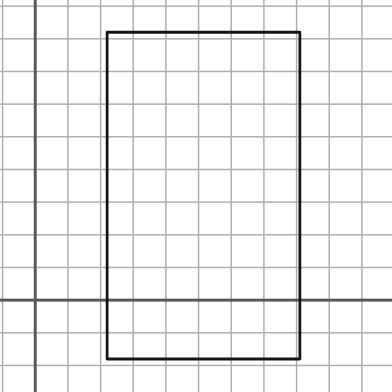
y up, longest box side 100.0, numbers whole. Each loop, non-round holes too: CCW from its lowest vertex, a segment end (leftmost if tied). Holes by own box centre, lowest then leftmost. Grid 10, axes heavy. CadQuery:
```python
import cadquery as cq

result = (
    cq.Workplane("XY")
    .moveTo(22.0, -18.0)
    .lineTo(81.0, -18.0)
    .lineTo(81.0, 82.0)
    .lineTo(22.0, 82.0)
    .close()
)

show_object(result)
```